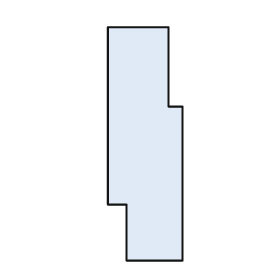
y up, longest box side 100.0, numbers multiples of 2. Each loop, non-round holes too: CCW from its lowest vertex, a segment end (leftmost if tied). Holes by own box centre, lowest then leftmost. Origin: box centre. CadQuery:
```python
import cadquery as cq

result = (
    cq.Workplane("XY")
    .moveTo(-8.0, -50.0)
    .lineTo(16.0, -50.0)
    .lineTo(16.0, 16.0)
    .lineTo(10.0, 16.0)
    .lineTo(10.0, 50.0)
    .lineTo(-16.0, 50.0)
    .lineTo(-16.0, -26.0)
    .lineTo(-8.0, -26.0)
    .close()
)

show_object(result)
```